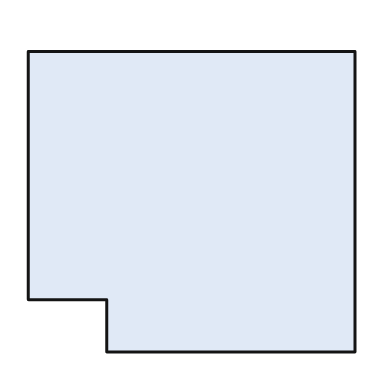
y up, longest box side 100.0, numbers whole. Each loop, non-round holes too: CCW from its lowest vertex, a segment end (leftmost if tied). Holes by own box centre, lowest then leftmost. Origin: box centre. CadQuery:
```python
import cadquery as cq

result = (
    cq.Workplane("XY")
    .moveTo(-26.0, -46.0)
    .lineTo(50.0, -46.0)
    .lineTo(50.0, 46.0)
    .lineTo(-50.0, 46.0)
    .lineTo(-50.0, -30.0)
    .lineTo(-26.0, -30.0)
    .close()
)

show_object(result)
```